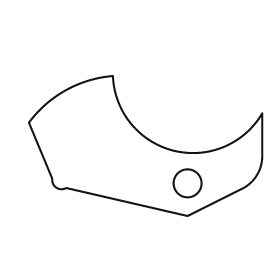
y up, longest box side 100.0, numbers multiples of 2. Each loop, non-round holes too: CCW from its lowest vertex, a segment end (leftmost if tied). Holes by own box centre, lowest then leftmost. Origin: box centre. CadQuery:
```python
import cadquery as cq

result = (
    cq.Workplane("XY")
    .moveTo(18.0, -30.0)
    .lineTo(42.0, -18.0)
    .threePointArc((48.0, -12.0), (50.0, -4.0))
    .lineTo(50.0, 14.0)
    .threePointArc((12.0, -2.0), (-14.0, 30.0))
    .threePointArc((-34.0, 24.0), (-50.0, 10.0))
    .lineTo(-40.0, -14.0)
    .threePointArc((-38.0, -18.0), (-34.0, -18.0))
    .close()
    .moveTo(18.0, -16.0)
    .circle(6.0)
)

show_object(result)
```